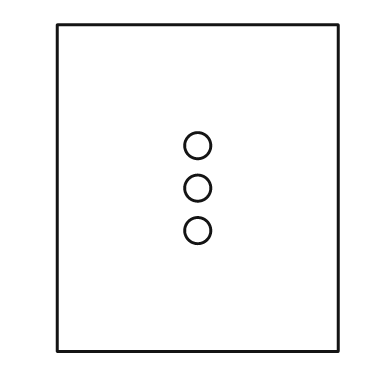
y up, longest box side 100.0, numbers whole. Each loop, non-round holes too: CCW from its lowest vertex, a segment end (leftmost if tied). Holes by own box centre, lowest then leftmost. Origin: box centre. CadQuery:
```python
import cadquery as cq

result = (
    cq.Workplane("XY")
    .moveTo(-43.0, -50.0)
    .lineTo(43.0, -50.0)
    .lineTo(43.0, 50.0)
    .lineTo(-43.0, 50.0)
    .close()
    .moveTo(0.0, -13.0)
    .circle(4.0)
    .moveTo(0.0, 0.0)
    .circle(4.0)
    .moveTo(0.0, 13.0)
    .circle(4.0)
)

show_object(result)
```